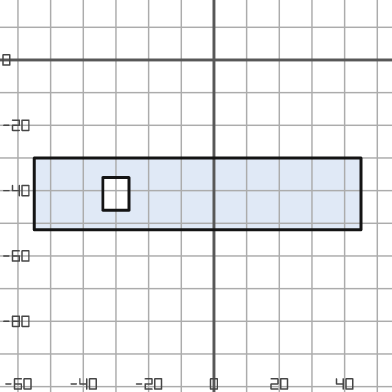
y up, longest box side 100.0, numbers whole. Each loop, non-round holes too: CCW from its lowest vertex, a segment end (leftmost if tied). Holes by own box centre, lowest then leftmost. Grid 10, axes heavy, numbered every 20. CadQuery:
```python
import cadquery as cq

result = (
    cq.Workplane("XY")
    .moveTo(-55.0, -52.0)
    .lineTo(45.0, -52.0)
    .lineTo(45.0, -30.0)
    .lineTo(-55.0, -30.0)
    .close()
    .moveTo(-34.0, -46.0)
    .lineTo(-26.0, -46.0)
    .lineTo(-26.0, -36.0)
    .lineTo(-34.0, -36.0)
    .close()
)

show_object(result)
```